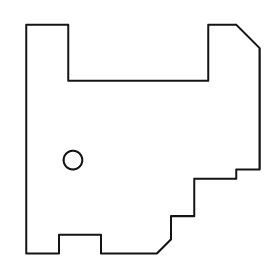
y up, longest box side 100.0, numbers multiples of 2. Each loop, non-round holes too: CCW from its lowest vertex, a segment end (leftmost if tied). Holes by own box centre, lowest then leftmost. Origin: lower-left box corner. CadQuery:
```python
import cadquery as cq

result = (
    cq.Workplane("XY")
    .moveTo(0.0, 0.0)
    .lineTo(14.0, 0.0)
    .lineTo(14.0, 8.0)
    .lineTo(32.0, 8.0)
    .lineTo(32.0, 0.0)
    .lineTo(56.0, 0.0)
    .lineTo(62.0, 6.0)
    .lineTo(62.0, 16.0)
    .lineTo(72.0, 16.0)
    .lineTo(72.0, 32.0)
    .lineTo(90.0, 32.0)
    .lineTo(90.0, 36.0)
    .lineTo(100.0, 36.0)
    .lineTo(100.0, 88.0)
    .lineTo(90.0, 98.0)
    .lineTo(78.0, 98.0)
    .lineTo(78.0, 74.0)
    .lineTo(18.0, 74.0)
    .lineTo(18.0, 98.0)
    .lineTo(0.0, 98.0)
    .close()
    .moveTo(20.0, 40.0)
    .circle(4.0)
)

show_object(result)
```